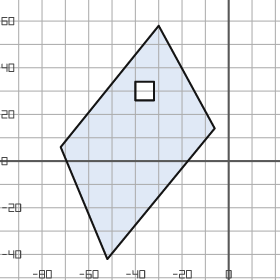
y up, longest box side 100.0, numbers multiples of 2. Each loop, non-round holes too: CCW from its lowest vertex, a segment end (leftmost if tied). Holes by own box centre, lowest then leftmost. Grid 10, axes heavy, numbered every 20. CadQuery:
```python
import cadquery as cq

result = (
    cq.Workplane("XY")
    .moveTo(-52.0, -42.0)
    .lineTo(-6.0, 14.0)
    .lineTo(-30.0, 58.0)
    .lineTo(-72.0, 6.0)
    .close()
    .moveTo(-40.0, 26.0)
    .lineTo(-32.0, 26.0)
    .lineTo(-32.0, 34.0)
    .lineTo(-40.0, 34.0)
    .close()
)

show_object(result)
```